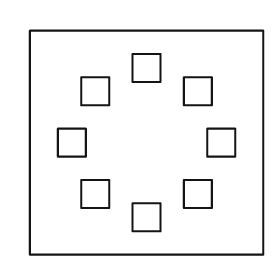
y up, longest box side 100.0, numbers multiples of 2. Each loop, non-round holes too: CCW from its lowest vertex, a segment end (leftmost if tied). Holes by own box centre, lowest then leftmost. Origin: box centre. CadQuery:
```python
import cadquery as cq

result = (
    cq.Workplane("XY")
    .moveTo(-50.0, -48.0)
    .lineTo(50.0, -48.0)
    .lineTo(50.0, 48.0)
    .lineTo(-50.0, 48.0)
    .close()
    .moveTo(-6.0, -38.0)
    .lineTo(6.0, -38.0)
    .lineTo(6.0, -26.0)
    .lineTo(-6.0, -26.0)
    .close()
    .moveTo(-28.0, -28.0)
    .lineTo(-16.0, -28.0)
    .lineTo(-16.0, -16.0)
    .lineTo(-28.0, -16.0)
    .close()
    .moveTo(16.0, -28.0)
    .lineTo(28.0, -28.0)
    .lineTo(28.0, -16.0)
    .lineTo(16.0, -16.0)
    .close()
    .moveTo(-38.0, -6.0)
    .lineTo(-26.0, -6.0)
    .lineTo(-26.0, 6.0)
    .lineTo(-38.0, 6.0)
    .close()
    .moveTo(26.0, -6.0)
    .lineTo(38.0, -6.0)
    .lineTo(38.0, 6.0)
    .lineTo(26.0, 6.0)
    .close()
    .moveTo(-28.0, 16.0)
    .lineTo(-16.0, 16.0)
    .lineTo(-16.0, 28.0)
    .lineTo(-28.0, 28.0)
    .close()
    .moveTo(16.0, 16.0)
    .lineTo(28.0, 16.0)
    .lineTo(28.0, 28.0)
    .lineTo(16.0, 28.0)
    .close()
    .moveTo(-6.0, 26.0)
    .lineTo(6.0, 26.0)
    .lineTo(6.0, 38.0)
    .lineTo(-6.0, 38.0)
    .close()
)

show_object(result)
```